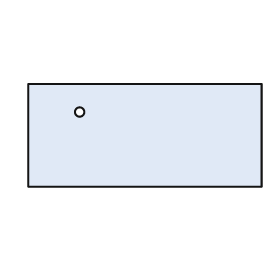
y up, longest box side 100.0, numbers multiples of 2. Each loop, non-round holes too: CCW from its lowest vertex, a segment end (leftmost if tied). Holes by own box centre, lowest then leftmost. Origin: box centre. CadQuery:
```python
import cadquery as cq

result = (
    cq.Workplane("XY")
    .moveTo(-50.0, -22.0)
    .lineTo(50.0, -22.0)
    .lineTo(50.0, 22.0)
    .lineTo(-50.0, 22.0)
    .close()
    .moveTo(-28.0, 10.0)
    .circle(2.0)
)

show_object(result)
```